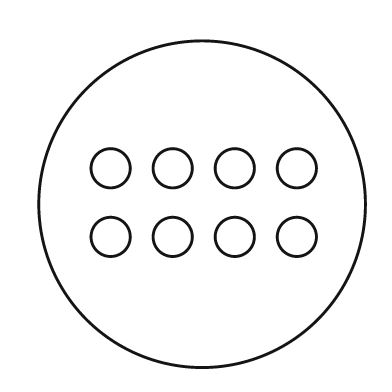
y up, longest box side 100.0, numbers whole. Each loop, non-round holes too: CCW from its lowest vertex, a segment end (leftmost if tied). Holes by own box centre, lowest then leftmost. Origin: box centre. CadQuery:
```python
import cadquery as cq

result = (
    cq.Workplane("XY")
    .moveTo(0.0, 0.0)
    .circle(50.0)
    .moveTo(-28.0, -10.0)
    .circle(6.0)
    .moveTo(-9.0, -10.0)
    .circle(6.0)
    .moveTo(10.0, -10.0)
    .circle(6.0)
    .moveTo(29.0, -10.0)
    .circle(6.0)
    .moveTo(-28.0, 11.0)
    .circle(6.0)
    .moveTo(-9.0, 11.0)
    .circle(6.0)
    .moveTo(10.0, 11.0)
    .circle(6.0)
    .moveTo(29.0, 11.0)
    .circle(6.0)
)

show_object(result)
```